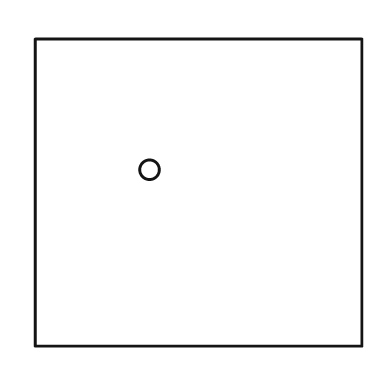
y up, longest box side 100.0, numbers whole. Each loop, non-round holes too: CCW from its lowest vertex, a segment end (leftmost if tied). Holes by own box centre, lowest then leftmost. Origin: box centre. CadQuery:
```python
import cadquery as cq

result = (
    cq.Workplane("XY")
    .moveTo(-50.0, -47.0)
    .lineTo(50.0, -47.0)
    .lineTo(50.0, 47.0)
    .lineTo(-50.0, 47.0)
    .close()
    .moveTo(-15.0, 7.0)
    .circle(3.0)
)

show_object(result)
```